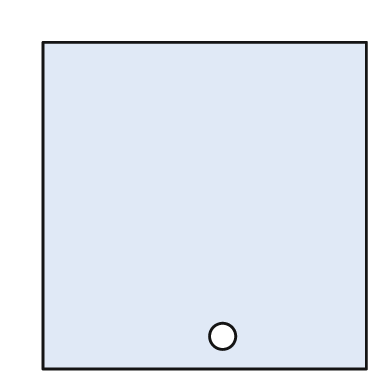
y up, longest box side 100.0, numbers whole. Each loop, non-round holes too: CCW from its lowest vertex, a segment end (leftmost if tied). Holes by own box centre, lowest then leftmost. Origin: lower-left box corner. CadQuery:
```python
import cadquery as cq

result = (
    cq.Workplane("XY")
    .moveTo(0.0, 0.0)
    .lineTo(99.0, 0.0)
    .lineTo(99.0, 100.0)
    .lineTo(0.0, 100.0)
    .close()
    .moveTo(55.0, 10.0)
    .circle(4.0)
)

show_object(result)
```